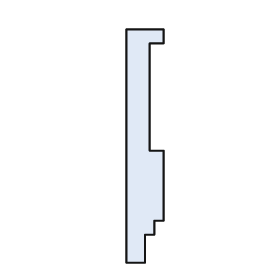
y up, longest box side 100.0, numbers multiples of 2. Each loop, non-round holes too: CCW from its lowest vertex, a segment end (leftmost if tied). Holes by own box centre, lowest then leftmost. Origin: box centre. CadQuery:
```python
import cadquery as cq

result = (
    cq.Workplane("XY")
    .moveTo(-8.0, -50.0)
    .lineTo(0.0, -50.0)
    .lineTo(0.0, -38.0)
    .lineTo(4.0, -38.0)
    .lineTo(4.0, -32.0)
    .lineTo(8.0, -32.0)
    .lineTo(8.0, -2.0)
    .lineTo(2.0, -2.0)
    .lineTo(2.0, 44.0)
    .lineTo(8.0, 44.0)
    .lineTo(8.0, 50.0)
    .lineTo(-8.0, 50.0)
    .close()
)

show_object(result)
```